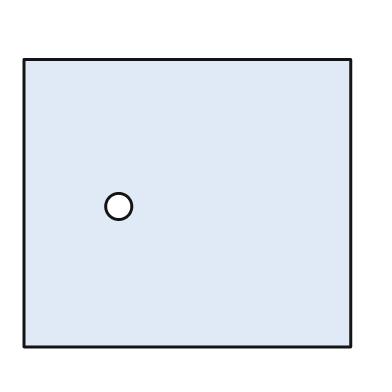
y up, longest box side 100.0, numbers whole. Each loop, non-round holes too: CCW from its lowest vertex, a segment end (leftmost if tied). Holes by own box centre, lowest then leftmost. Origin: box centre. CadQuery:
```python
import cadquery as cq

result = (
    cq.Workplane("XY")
    .moveTo(-50.0, -44.0)
    .lineTo(50.0, -44.0)
    .lineTo(50.0, 44.0)
    .lineTo(-50.0, 44.0)
    .close()
    .moveTo(-21.0, -1.0)
    .circle(4.0)
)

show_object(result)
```